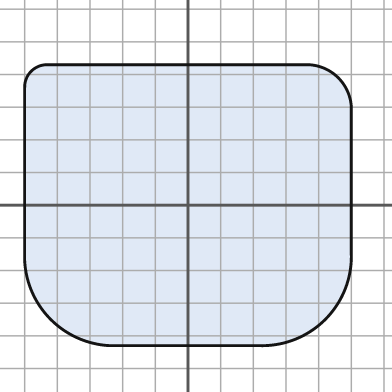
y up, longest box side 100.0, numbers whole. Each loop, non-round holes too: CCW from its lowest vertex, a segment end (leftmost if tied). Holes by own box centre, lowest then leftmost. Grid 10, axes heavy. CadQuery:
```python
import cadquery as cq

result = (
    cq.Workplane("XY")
    .moveTo(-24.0, -43.0)
    .lineTo(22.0, -43.0)
    .threePointArc((42.0, -35.0), (50.0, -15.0))
    .lineTo(50.0, 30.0)
    .threePointArc((46.0, 39.0), (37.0, 43.0))
    .lineTo(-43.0, 43.0)
    .threePointArc((-48.0, 41.0), (-50.0, 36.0))
    .lineTo(-50.0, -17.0)
    .threePointArc((-42.0, -35.0), (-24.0, -43.0))
    .close()
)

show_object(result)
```